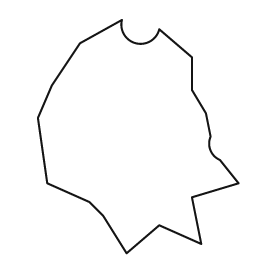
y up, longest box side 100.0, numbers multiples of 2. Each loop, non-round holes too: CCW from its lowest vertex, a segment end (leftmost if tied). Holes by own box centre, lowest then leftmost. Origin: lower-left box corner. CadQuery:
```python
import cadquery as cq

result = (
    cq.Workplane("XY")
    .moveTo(38.0, 0.0)
    .lineTo(52.0, 12.0)
    .lineTo(70.0, 4.0)
    .lineTo(66.0, 24.0)
    .lineTo(86.0, 30.0)
    .lineTo(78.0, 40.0)
    .threePointArc((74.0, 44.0), (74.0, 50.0))
    .lineTo(72.0, 60.0)
    .lineTo(66.0, 70.0)
    .lineTo(66.0, 84.0)
    .lineTo(52.0, 96.0)
    .threePointArc((42.0, 90.0), (36.0, 100.0))
    .lineTo(18.0, 90.0)
    .lineTo(6.0, 72.0)
    .lineTo(0.0, 58.0)
    .lineTo(4.0, 30.0)
    .lineTo(22.0, 22.0)
    .lineTo(28.0, 16.0)
    .close()
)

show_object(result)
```